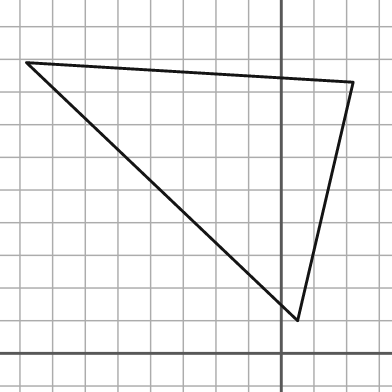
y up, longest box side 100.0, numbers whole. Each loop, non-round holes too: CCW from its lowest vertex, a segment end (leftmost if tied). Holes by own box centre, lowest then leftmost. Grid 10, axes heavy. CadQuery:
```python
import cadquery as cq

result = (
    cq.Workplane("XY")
    .moveTo(5.0, 10.0)
    .lineTo(22.0, 83.0)
    .lineTo(-78.0, 89.0)
    .close()
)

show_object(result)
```